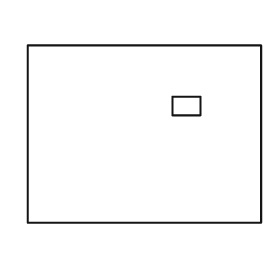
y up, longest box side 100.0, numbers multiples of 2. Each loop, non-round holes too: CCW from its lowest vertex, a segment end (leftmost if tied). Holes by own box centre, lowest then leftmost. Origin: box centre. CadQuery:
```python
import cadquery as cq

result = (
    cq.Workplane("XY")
    .moveTo(-50.0, -38.0)
    .lineTo(50.0, -38.0)
    .lineTo(50.0, 38.0)
    .lineTo(-50.0, 38.0)
    .close()
    .moveTo(12.0, 8.0)
    .lineTo(24.0, 8.0)
    .lineTo(24.0, 16.0)
    .lineTo(12.0, 16.0)
    .close()
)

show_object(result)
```